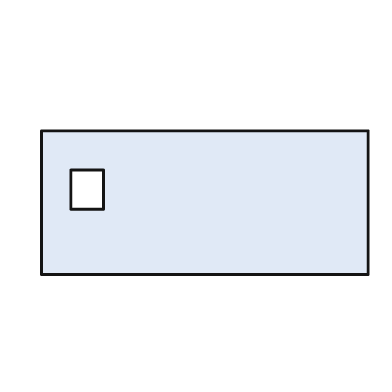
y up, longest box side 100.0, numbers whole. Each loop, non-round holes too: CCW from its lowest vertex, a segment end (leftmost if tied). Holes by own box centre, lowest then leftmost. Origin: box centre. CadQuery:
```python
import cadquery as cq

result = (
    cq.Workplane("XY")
    .moveTo(-50.0, -22.0)
    .lineTo(50.0, -22.0)
    .lineTo(50.0, 22.0)
    .lineTo(-50.0, 22.0)
    .close()
    .moveTo(-41.0, -2.0)
    .lineTo(-31.0, -2.0)
    .lineTo(-31.0, 10.0)
    .lineTo(-41.0, 10.0)
    .close()
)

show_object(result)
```